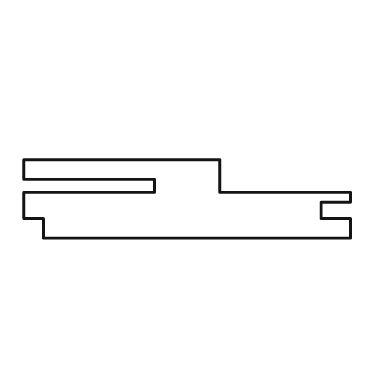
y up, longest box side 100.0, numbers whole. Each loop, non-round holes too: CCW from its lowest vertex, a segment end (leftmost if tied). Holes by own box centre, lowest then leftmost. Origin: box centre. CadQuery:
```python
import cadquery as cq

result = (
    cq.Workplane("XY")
    .moveTo(-44.0, -12.0)
    .lineTo(50.0, -12.0)
    .lineTo(50.0, -6.0)
    .lineTo(41.0, -6.0)
    .lineTo(41.0, -1.0)
    .lineTo(50.0, -1.0)
    .lineTo(50.0, 2.0)
    .lineTo(10.0, 2.0)
    .lineTo(10.0, 12.0)
    .lineTo(-50.0, 12.0)
    .lineTo(-50.0, 6.0)
    .lineTo(-10.0, 6.0)
    .lineTo(-10.0, 2.0)
    .lineTo(-50.0, 2.0)
    .lineTo(-50.0, -6.0)
    .lineTo(-44.0, -6.0)
    .close()
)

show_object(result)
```